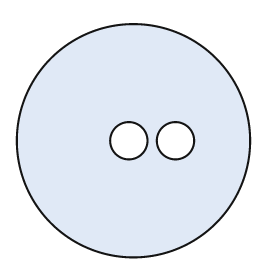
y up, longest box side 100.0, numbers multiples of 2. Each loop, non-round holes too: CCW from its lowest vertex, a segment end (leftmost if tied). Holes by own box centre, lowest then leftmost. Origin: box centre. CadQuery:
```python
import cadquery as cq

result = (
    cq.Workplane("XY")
    .moveTo(0.0, 0.0)
    .circle(50.0)
    .moveTo(-2.0, 0.0)
    .circle(8.0)
    .moveTo(18.0, 0.0)
    .circle(8.0)
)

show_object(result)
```